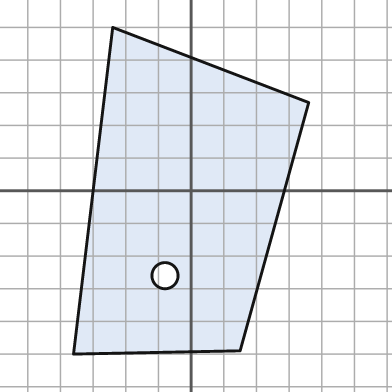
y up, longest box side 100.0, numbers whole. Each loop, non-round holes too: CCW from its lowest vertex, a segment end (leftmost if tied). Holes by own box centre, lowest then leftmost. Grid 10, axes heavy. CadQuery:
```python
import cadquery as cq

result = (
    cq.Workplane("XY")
    .moveTo(-36.0, -50.0)
    .lineTo(15.0, -49.0)
    .lineTo(36.0, 27.0)
    .lineTo(-24.0, 50.0)
    .close()
    .moveTo(-8.0, -26.0)
    .circle(4.0)
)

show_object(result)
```